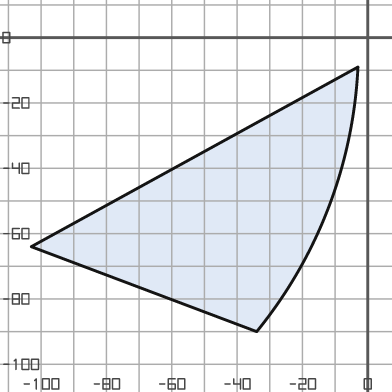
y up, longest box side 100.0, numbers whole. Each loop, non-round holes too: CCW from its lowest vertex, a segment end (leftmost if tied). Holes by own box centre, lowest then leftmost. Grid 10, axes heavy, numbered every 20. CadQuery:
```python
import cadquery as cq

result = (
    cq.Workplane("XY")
    .moveTo(-34.0, -90.0)
    .threePointArc((-12.0, -52.0), (-3.0, -9.0))
    .lineTo(-103.0, -64.0)
    .close()
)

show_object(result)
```